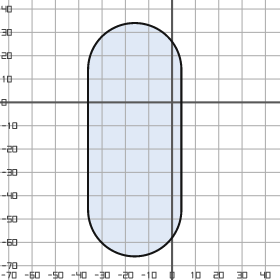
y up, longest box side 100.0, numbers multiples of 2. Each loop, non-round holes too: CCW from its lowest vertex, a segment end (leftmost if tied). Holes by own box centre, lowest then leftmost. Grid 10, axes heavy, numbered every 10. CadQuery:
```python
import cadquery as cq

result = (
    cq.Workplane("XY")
    .moveTo(-36.0, -46.0)
    .threePointArc((-16.0, -66.0), (4.0, -46.0))
    .lineTo(4.0, 14.0)
    .threePointArc((-16.0, 34.0), (-36.0, 14.0))
    .close()
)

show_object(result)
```